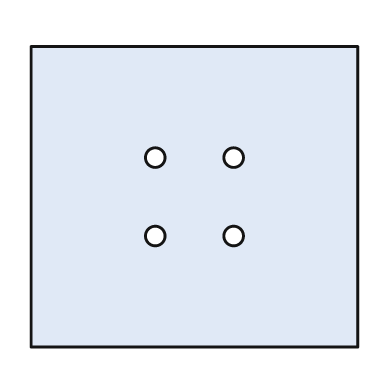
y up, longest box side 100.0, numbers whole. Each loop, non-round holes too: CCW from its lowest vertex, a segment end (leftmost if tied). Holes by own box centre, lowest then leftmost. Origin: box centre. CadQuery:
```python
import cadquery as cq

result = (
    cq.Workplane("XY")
    .moveTo(-50.0, -46.0)
    .lineTo(50.0, -46.0)
    .lineTo(50.0, 46.0)
    .lineTo(-50.0, 46.0)
    .close()
    .moveTo(-12.0, -12.0)
    .circle(3.0)
    .moveTo(12.0, -12.0)
    .circle(3.0)
    .moveTo(-12.0, 12.0)
    .circle(3.0)
    .moveTo(12.0, 12.0)
    .circle(3.0)
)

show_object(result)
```